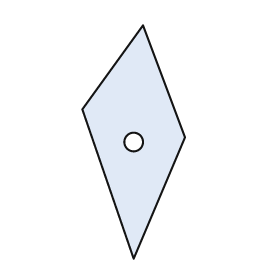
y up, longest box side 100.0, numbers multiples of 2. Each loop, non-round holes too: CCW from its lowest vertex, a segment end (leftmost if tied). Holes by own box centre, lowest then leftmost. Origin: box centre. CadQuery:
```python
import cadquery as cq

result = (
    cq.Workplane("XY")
    .moveTo(0.0, -50.0)
    .lineTo(22.0, 2.0)
    .lineTo(4.0, 50.0)
    .lineTo(-22.0, 14.0)
    .close()
    .moveTo(0.0, 0.0)
    .circle(4.0)
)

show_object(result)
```